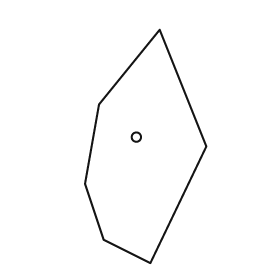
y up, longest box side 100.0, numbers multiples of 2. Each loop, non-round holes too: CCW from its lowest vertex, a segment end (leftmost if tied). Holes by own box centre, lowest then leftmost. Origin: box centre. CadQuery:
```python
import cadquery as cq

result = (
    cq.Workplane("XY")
    .moveTo(2.0, -50.0)
    .lineTo(26.0, 0.0)
    .lineTo(6.0, 50.0)
    .lineTo(-20.0, 18.0)
    .lineTo(-26.0, -16.0)
    .lineTo(-18.0, -40.0)
    .close()
    .moveTo(-4.0, 4.0)
    .circle(2.0)
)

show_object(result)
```